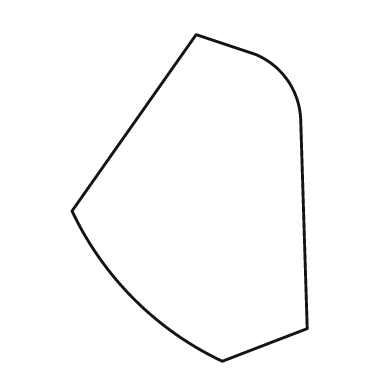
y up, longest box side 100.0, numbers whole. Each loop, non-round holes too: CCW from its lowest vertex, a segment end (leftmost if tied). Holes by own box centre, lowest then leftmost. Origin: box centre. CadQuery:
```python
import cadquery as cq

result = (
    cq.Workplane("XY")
    .moveTo(10.0, -50.0)
    .lineTo(36.0, -40.0)
    .lineTo(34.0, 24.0)
    .threePointArc((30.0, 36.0), (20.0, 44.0))
    .lineTo(2.0, 50.0)
    .lineTo(-36.0, -4.0)
    .threePointArc((-17.0, -31.0), (10.0, -50.0))
    .close()
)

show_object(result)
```